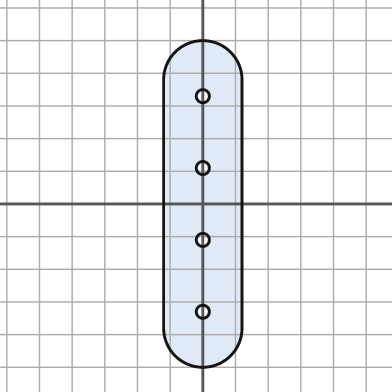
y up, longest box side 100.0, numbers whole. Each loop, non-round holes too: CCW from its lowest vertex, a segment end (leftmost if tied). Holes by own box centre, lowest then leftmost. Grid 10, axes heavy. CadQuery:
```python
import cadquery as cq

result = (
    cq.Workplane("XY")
    .moveTo(-12.0, -38.0)
    .threePointArc((0.0, -50.0), (12.0, -38.0))
    .lineTo(12.0, 38.0)
    .threePointArc((0.0, 50.0), (-12.0, 38.0))
    .close()
    .moveTo(0.0, -33.0)
    .circle(2.0)
    .moveTo(0.0, -11.0)
    .circle(2.0)
    .moveTo(0.0, 11.0)
    .circle(2.0)
    .moveTo(0.0, 33.0)
    .circle(2.0)
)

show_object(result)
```